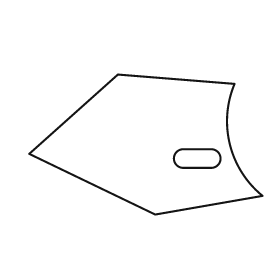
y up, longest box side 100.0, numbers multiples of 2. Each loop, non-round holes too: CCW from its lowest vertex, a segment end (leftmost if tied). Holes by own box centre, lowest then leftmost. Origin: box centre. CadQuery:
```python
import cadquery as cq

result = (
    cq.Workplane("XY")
    .moveTo(4.0, -30.0)
    .lineTo(50.0, -22.0)
    .threePointArc((36.0, 0.0), (38.0, 26.0))
    .lineTo(-12.0, 30.0)
    .lineTo(-50.0, -4.0)
    .close()
    .moveTo(16.0, -10.0)
    .lineTo(28.0, -10.0)
    .threePointArc((32.0, -6.0), (28.0, -2.0))
    .lineTo(16.0, -2.0)
    .threePointArc((12.0, -6.0), (16.0, -10.0))
    .close()
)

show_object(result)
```